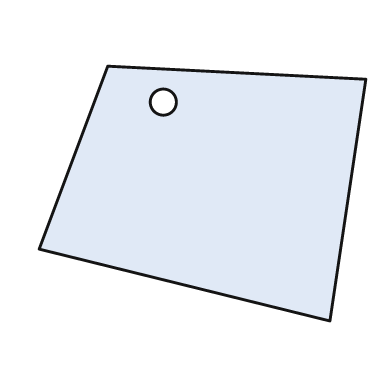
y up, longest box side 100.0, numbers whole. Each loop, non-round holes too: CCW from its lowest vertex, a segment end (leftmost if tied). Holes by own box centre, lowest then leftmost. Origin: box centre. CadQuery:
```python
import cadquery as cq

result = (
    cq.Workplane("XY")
    .moveTo(39.0, -39.0)
    .lineTo(50.0, 35.0)
    .lineTo(-29.0, 39.0)
    .lineTo(-50.0, -17.0)
    .close()
    .moveTo(-12.0, 28.0)
    .circle(4.0)
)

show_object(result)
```